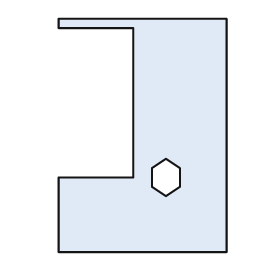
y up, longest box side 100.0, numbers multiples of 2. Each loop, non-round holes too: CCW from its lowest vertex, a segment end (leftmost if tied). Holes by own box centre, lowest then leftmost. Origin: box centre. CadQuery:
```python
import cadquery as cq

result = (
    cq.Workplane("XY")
    .moveTo(-36.0, -50.0)
    .lineTo(36.0, -50.0)
    .lineTo(36.0, 50.0)
    .lineTo(-36.0, 50.0)
    .lineTo(-36.0, 46.0)
    .lineTo(-4.0, 46.0)
    .lineTo(-4.0, -18.0)
    .lineTo(-36.0, -18.0)
    .close()
    .moveTo(10.0, -26.0)
    .lineTo(16.0, -22.0)
    .lineTo(16.0, -14.0)
    .lineTo(10.0, -10.0)
    .lineTo(4.0, -14.0)
    .lineTo(4.0, -22.0)
    .close()
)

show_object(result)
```